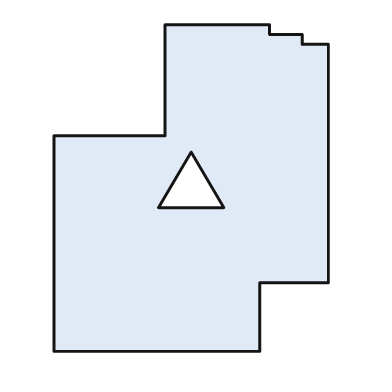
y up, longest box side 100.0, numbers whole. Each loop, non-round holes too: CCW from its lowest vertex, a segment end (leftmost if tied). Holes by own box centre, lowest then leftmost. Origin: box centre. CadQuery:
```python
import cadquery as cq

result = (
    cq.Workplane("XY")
    .moveTo(-42.0, -50.0)
    .lineTo(21.0, -50.0)
    .lineTo(21.0, -29.0)
    .lineTo(42.0, -29.0)
    .lineTo(42.0, 44.0)
    .lineTo(34.0, 44.0)
    .lineTo(34.0, 47.0)
    .lineTo(24.0, 47.0)
    .lineTo(24.0, 50.0)
    .lineTo(-8.0, 50.0)
    .lineTo(-8.0, 16.0)
    .lineTo(-42.0, 16.0)
    .close()
    .moveTo(-10.0, -6.0)
    .lineTo(10.0, -6.0)
    .lineTo(0.0, 11.0)
    .close()
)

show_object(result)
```